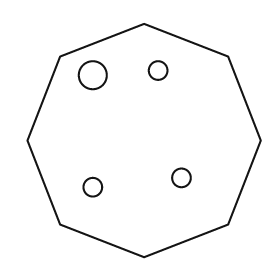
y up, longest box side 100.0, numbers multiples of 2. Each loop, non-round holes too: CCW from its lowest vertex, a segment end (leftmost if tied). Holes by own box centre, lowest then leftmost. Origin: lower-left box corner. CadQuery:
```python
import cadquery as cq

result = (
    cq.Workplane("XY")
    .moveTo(50.0, 0.0)
    .lineTo(86.0, 14.0)
    .lineTo(100.0, 50.0)
    .lineTo(86.0, 86.0)
    .lineTo(50.0, 100.0)
    .lineTo(14.0, 86.0)
    .lineTo(0.0, 50.0)
    .lineTo(14.0, 14.0)
    .close()
    .moveTo(28.0, 30.0)
    .circle(4.0)
    .moveTo(66.0, 34.0)
    .circle(4.0)
    .moveTo(28.0, 78.0)
    .circle(6.0)
    .moveTo(56.0, 80.0)
    .circle(4.0)
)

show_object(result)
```